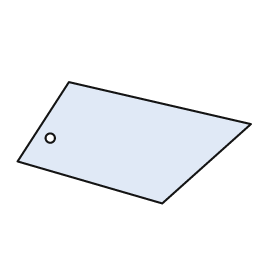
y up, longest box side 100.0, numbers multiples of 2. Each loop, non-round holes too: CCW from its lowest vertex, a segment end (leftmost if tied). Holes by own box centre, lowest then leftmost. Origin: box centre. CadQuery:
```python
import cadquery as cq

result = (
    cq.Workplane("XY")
    .moveTo(12.0, -26.0)
    .lineTo(50.0, 8.0)
    .lineTo(-28.0, 26.0)
    .lineTo(-50.0, -8.0)
    .close()
    .moveTo(-36.0, 2.0)
    .circle(2.0)
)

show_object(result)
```